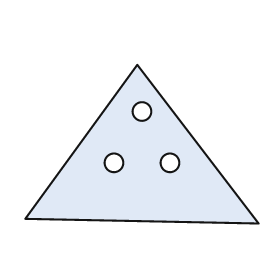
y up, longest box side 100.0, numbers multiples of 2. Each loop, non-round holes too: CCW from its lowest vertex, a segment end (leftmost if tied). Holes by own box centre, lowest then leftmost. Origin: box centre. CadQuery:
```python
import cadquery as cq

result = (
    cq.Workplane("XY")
    .moveTo(50.0, -34.0)
    .lineTo(-2.0, 34.0)
    .lineTo(-50.0, -32.0)
    .close()
    .moveTo(-12.0, -8.0)
    .circle(4.0)
    .moveTo(12.0, -8.0)
    .circle(4.0)
    .moveTo(0.0, 14.0)
    .circle(4.0)
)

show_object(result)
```